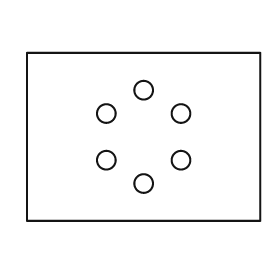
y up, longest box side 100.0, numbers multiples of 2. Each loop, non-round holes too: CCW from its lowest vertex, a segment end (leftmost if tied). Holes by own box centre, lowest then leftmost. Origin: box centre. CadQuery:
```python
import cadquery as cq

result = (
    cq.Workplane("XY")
    .moveTo(-50.0, -36.0)
    .lineTo(50.0, -36.0)
    .lineTo(50.0, 36.0)
    .lineTo(-50.0, 36.0)
    .close()
    .moveTo(0.0, -20.0)
    .circle(4.0)
    .moveTo(-16.0, -10.0)
    .circle(4.0)
    .moveTo(16.0, -10.0)
    .circle(4.0)
    .moveTo(-16.0, 10.0)
    .circle(4.0)
    .moveTo(16.0, 10.0)
    .circle(4.0)
    .moveTo(0.0, 20.0)
    .circle(4.0)
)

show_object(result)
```